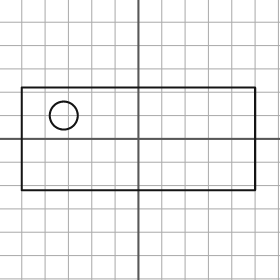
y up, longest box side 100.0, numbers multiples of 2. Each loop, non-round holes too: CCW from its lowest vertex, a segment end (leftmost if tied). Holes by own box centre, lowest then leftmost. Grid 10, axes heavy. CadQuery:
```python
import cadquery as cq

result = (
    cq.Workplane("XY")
    .moveTo(-50.0, -22.0)
    .lineTo(50.0, -22.0)
    .lineTo(50.0, 22.0)
    .lineTo(-50.0, 22.0)
    .close()
    .moveTo(-32.0, 10.0)
    .circle(6.0)
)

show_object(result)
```